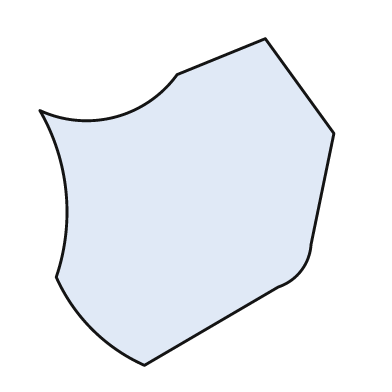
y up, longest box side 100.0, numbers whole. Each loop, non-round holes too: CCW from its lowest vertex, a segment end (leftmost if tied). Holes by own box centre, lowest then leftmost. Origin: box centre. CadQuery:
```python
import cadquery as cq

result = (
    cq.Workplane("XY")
    .moveTo(-13.0, -50.0)
    .lineTo(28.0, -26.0)
    .threePointArc((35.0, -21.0), (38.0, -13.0))
    .lineTo(45.0, 21.0)
    .lineTo(24.0, 50.0)
    .lineTo(-3.0, 39.0)
    .threePointArc((-22.0, 26.0), (-45.0, 28.0))
    .threePointArc((-37.0, 3.0), (-40.0, -23.0))
    .threePointArc((-29.0, -39.0), (-13.0, -50.0))
    .close()
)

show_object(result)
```